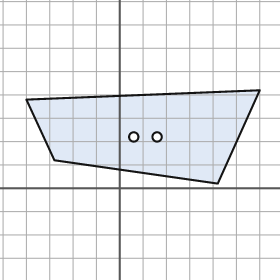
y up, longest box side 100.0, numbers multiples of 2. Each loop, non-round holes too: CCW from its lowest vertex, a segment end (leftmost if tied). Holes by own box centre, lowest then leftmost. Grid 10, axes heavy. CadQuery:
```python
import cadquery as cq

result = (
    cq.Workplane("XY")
    .moveTo(42.0, 2.0)
    .lineTo(60.0, 42.0)
    .lineTo(-40.0, 38.0)
    .lineTo(-28.0, 12.0)
    .close()
    .moveTo(6.0, 22.0)
    .circle(2.0)
    .moveTo(16.0, 22.0)
    .circle(2.0)
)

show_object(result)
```